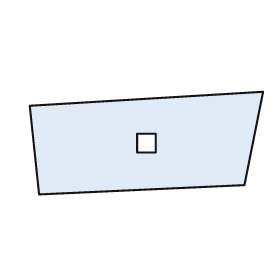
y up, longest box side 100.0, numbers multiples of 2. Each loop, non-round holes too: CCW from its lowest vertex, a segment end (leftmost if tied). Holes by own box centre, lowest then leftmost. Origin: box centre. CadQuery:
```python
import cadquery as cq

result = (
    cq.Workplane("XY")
    .moveTo(-46.0, -22.0)
    .lineTo(42.0, -18.0)
    .lineTo(50.0, 22.0)
    .lineTo(-50.0, 16.0)
    .close()
    .moveTo(-4.0, -4.0)
    .lineTo(4.0, -4.0)
    .lineTo(4.0, 4.0)
    .lineTo(-4.0, 4.0)
    .close()
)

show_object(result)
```